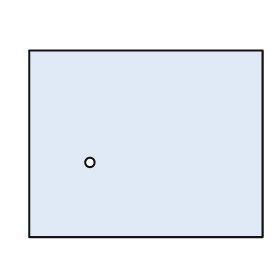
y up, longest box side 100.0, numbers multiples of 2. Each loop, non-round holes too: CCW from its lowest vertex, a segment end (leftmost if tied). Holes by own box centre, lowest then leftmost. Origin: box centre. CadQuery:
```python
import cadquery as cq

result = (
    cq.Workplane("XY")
    .moveTo(-50.0, -40.0)
    .lineTo(50.0, -40.0)
    .lineTo(50.0, 40.0)
    .lineTo(-50.0, 40.0)
    .close()
    .moveTo(-24.0, -8.0)
    .circle(2.0)
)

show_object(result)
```